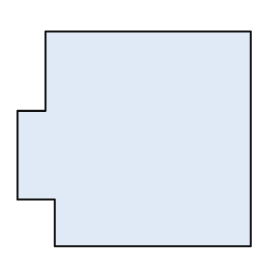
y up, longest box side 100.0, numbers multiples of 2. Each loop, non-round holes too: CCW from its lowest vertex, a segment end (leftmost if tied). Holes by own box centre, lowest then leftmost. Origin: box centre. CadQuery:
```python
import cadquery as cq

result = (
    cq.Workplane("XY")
    .moveTo(-34.0, -46.0)
    .lineTo(50.0, -46.0)
    .lineTo(50.0, 46.0)
    .lineTo(-38.0, 46.0)
    .lineTo(-38.0, 12.0)
    .lineTo(-50.0, 12.0)
    .lineTo(-50.0, -26.0)
    .lineTo(-34.0, -26.0)
    .close()
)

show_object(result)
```